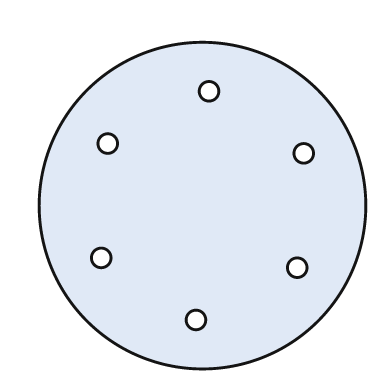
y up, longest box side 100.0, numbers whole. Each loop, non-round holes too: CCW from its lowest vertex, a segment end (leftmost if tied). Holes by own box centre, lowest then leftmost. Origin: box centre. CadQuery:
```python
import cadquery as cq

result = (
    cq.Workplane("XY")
    .moveTo(0.0, 0.0)
    .circle(50.0)
    .moveTo(-2.0, -35.0)
    .circle(3.0)
    .moveTo(29.0, -19.0)
    .circle(3.0)
    .moveTo(-31.0, -16.0)
    .circle(3.0)
    .moveTo(31.0, 16.0)
    .circle(3.0)
    .moveTo(-29.0, 19.0)
    .circle(3.0)
    .moveTo(2.0, 35.0)
    .circle(3.0)
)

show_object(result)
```